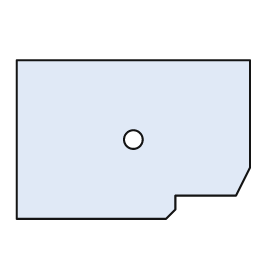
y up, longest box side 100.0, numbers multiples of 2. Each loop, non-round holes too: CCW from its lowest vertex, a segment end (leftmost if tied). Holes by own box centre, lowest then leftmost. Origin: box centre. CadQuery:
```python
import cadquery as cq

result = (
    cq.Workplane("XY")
    .moveTo(-50.0, -34.0)
    .lineTo(14.0, -34.0)
    .lineTo(18.0, -30.0)
    .lineTo(18.0, -24.0)
    .lineTo(44.0, -24.0)
    .lineTo(50.0, -12.0)
    .lineTo(50.0, 34.0)
    .lineTo(-50.0, 34.0)
    .close()
    .moveTo(0.0, 0.0)
    .circle(4.0)
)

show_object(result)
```